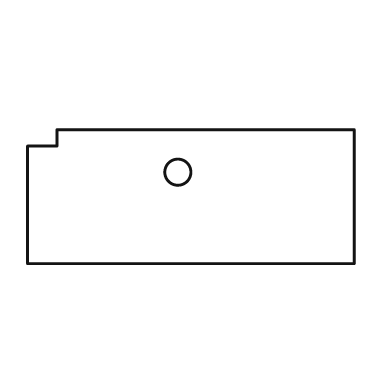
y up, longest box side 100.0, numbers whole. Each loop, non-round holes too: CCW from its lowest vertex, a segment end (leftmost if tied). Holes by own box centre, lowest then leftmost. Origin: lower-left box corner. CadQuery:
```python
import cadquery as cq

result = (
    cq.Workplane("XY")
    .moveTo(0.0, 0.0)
    .lineTo(100.0, 0.0)
    .lineTo(100.0, 41.0)
    .lineTo(9.0, 41.0)
    .lineTo(9.0, 36.0)
    .lineTo(0.0, 36.0)
    .close()
    .moveTo(46.0, 28.0)
    .circle(4.0)
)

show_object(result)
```